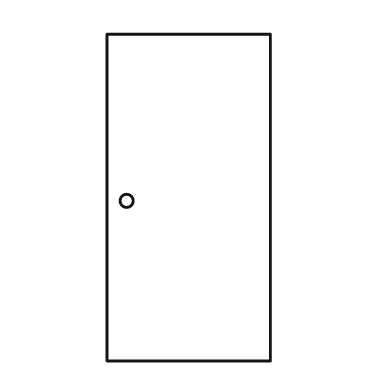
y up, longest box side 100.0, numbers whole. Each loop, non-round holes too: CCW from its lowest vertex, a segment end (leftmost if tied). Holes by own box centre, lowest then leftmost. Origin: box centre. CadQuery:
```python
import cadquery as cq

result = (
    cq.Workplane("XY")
    .moveTo(-25.0, -50.0)
    .lineTo(25.0, -50.0)
    .lineTo(25.0, 50.0)
    .lineTo(-25.0, 50.0)
    .close()
    .moveTo(-19.0, -1.0)
    .circle(2.0)
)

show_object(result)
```